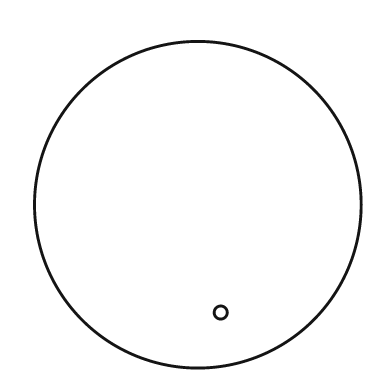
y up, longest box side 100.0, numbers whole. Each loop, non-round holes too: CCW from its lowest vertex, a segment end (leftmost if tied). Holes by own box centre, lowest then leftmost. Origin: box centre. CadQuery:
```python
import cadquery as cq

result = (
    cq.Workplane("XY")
    .moveTo(0.0, 0.0)
    .circle(50.0)
    .moveTo(7.0, -33.0)
    .circle(2.0)
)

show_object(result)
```